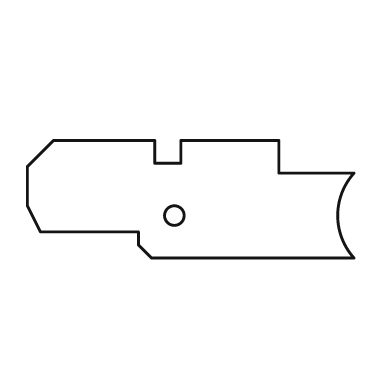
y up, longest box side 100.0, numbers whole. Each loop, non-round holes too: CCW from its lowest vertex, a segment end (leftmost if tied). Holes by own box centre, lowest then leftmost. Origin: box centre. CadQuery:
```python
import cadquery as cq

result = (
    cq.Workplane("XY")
    .moveTo(-12.0, -18.0)
    .lineTo(50.0, -18.0)
    .threePointArc((45.0, -5.0), (50.0, 8.0))
    .lineTo(27.0, 8.0)
    .lineTo(27.0, 18.0)
    .lineTo(-3.0, 18.0)
    .lineTo(-3.0, 11.0)
    .lineTo(-11.0, 11.0)
    .lineTo(-11.0, 18.0)
    .lineTo(-42.0, 18.0)
    .lineTo(-50.0, 10.0)
    .lineTo(-50.0, -2.0)
    .lineTo(-46.0, -10.0)
    .lineTo(-16.0, -10.0)
    .lineTo(-16.0, -14.0)
    .close()
    .moveTo(-5.0, -5.0)
    .circle(3.0)
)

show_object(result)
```